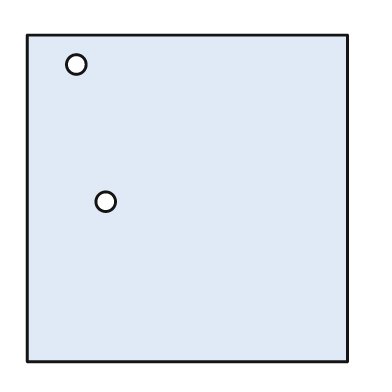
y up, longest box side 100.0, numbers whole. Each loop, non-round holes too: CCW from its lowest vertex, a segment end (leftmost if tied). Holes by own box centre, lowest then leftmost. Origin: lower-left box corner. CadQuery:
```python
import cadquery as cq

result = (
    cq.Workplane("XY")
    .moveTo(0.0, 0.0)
    .lineTo(98.0, 0.0)
    .lineTo(98.0, 100.0)
    .lineTo(0.0, 100.0)
    .close()
    .moveTo(24.0, 49.0)
    .circle(3.0)
    .moveTo(15.0, 91.0)
    .circle(3.0)
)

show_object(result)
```